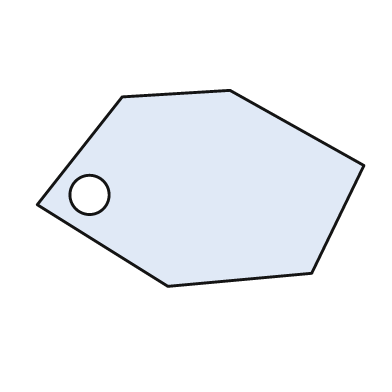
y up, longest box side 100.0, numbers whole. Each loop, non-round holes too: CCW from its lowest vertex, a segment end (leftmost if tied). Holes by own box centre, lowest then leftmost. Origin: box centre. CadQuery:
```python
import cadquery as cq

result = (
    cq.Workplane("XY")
    .moveTo(-10.0, -30.0)
    .lineTo(34.0, -26.0)
    .lineTo(50.0, 7.0)
    .lineTo(9.0, 30.0)
    .lineTo(-24.0, 28.0)
    .lineTo(-50.0, -5.0)
    .close()
    .moveTo(-34.0, -2.0)
    .circle(6.0)
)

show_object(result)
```